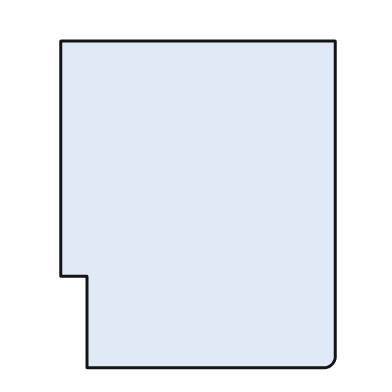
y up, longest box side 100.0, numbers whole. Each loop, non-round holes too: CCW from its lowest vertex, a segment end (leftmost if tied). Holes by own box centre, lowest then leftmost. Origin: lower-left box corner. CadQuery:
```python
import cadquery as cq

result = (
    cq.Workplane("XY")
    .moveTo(8.0, 0.0)
    .lineTo(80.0, 0.0)
    .threePointArc((83.0, 1.0), (84.0, 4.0))
    .lineTo(84.0, 100.0)
    .lineTo(0.0, 100.0)
    .lineTo(0.0, 28.0)
    .lineTo(8.0, 28.0)
    .close()
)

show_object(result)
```